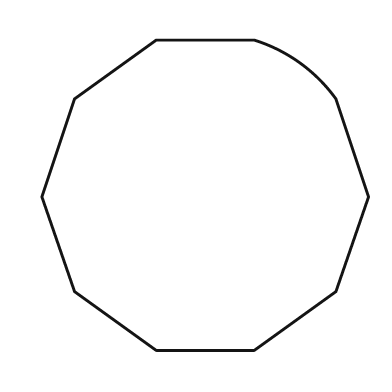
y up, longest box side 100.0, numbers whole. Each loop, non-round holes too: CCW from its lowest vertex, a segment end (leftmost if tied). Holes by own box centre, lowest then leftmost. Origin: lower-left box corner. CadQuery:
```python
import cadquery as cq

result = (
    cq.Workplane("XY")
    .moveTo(35.0, 0.0)
    .lineTo(65.0, 0.0)
    .lineTo(90.0, 18.0)
    .lineTo(100.0, 47.0)
    .lineTo(90.0, 77.0)
    .threePointArc((79.0, 88.0), (65.0, 95.0))
    .lineTo(35.0, 95.0)
    .lineTo(10.0, 77.0)
    .lineTo(0.0, 47.0)
    .lineTo(10.0, 18.0)
    .close()
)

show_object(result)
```